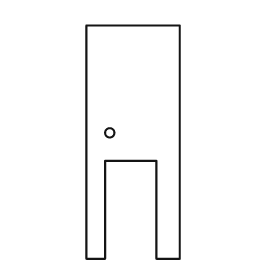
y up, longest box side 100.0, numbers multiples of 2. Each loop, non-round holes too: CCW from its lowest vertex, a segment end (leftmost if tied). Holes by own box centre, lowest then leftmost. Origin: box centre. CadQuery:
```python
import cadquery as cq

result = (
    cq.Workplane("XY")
    .moveTo(-20.0, -50.0)
    .lineTo(-12.0, -50.0)
    .lineTo(-12.0, -8.0)
    .lineTo(10.0, -8.0)
    .lineTo(10.0, -50.0)
    .lineTo(20.0, -50.0)
    .lineTo(20.0, 50.0)
    .lineTo(-20.0, 50.0)
    .close()
    .moveTo(-10.0, 4.0)
    .circle(2.0)
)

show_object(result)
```